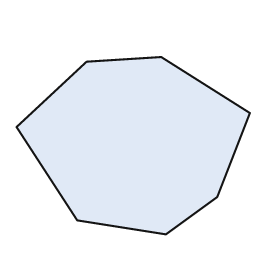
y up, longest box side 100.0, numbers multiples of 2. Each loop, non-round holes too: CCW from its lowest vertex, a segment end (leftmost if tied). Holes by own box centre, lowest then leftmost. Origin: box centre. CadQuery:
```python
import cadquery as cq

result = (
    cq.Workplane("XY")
    .moveTo(14.0, -38.0)
    .lineTo(36.0, -22.0)
    .lineTo(50.0, 14.0)
    .lineTo(12.0, 38.0)
    .lineTo(-20.0, 36.0)
    .lineTo(-50.0, 8.0)
    .lineTo(-24.0, -32.0)
    .close()
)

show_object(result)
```